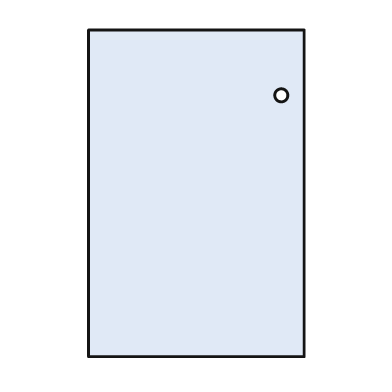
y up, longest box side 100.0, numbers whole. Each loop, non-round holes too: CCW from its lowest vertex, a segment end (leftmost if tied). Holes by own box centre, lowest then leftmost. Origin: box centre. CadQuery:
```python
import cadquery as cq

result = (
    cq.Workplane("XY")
    .moveTo(-33.0, -50.0)
    .lineTo(33.0, -50.0)
    .lineTo(33.0, 50.0)
    .lineTo(-33.0, 50.0)
    .close()
    .moveTo(26.0, 30.0)
    .circle(2.0)
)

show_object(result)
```